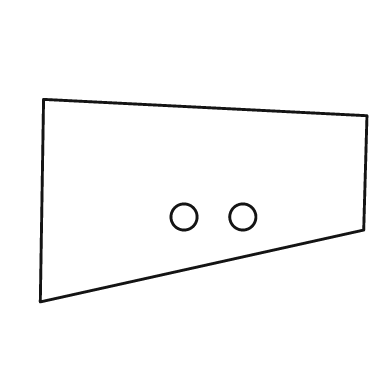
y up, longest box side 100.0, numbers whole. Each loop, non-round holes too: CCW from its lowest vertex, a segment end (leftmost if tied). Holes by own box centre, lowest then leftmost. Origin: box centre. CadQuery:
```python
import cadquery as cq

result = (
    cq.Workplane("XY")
    .moveTo(-50.0, -31.0)
    .lineTo(49.0, -9.0)
    .lineTo(50.0, 26.0)
    .lineTo(-49.0, 31.0)
    .close()
    .moveTo(-6.0, -5.0)
    .circle(4.0)
    .moveTo(12.0, -5.0)
    .circle(4.0)
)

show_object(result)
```